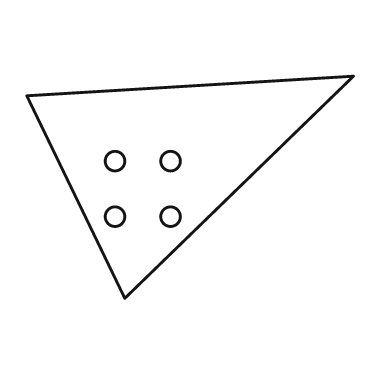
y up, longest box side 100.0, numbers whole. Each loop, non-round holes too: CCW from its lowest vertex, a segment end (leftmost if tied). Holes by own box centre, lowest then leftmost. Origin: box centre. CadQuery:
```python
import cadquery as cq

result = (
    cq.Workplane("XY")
    .moveTo(-20.0, -34.0)
    .lineTo(50.0, 34.0)
    .lineTo(-50.0, 28.0)
    .close()
    .moveTo(-23.0, -9.0)
    .circle(3.0)
    .moveTo(-6.0, -9.0)
    .circle(3.0)
    .moveTo(-23.0, 8.0)
    .circle(3.0)
    .moveTo(-6.0, 8.0)
    .circle(3.0)
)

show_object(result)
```